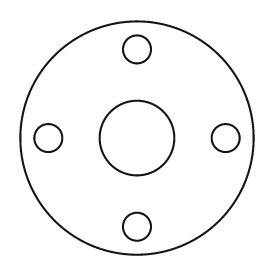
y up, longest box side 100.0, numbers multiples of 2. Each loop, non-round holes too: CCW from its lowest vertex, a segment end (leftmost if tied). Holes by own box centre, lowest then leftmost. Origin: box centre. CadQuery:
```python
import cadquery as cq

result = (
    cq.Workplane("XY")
    .moveTo(0.0, 0.0)
    .circle(50.0)
    .moveTo(0.0, -38.0)
    .circle(6.0)
    .moveTo(-38.0, 0.0)
    .circle(6.0)
    .moveTo(0.0, 0.0)
    .circle(16.0)
    .moveTo(38.0, 0.0)
    .circle(6.0)
    .moveTo(0.0, 38.0)
    .circle(6.0)
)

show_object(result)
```